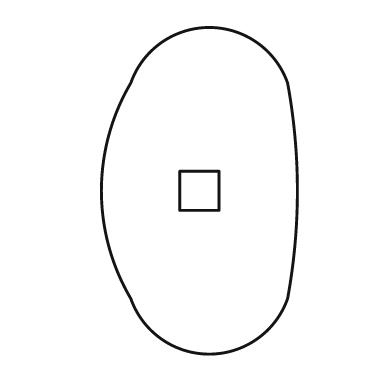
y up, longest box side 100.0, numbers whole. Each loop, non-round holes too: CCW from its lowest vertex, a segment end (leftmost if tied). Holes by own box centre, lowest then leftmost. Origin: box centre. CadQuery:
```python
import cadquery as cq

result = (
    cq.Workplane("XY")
    .moveTo(-21.0, -33.0)
    .threePointArc((3.0, -50.0), (27.0, -33.0))
    .threePointArc((30.0, 0.0), (27.0, 33.0))
    .threePointArc((3.0, 50.0), (-21.0, 33.0))
    .threePointArc((-30.0, 0.0), (-21.0, -33.0))
    .close()
    .moveTo(-6.0, -6.0)
    .lineTo(6.0, -6.0)
    .lineTo(6.0, 6.0)
    .lineTo(-6.0, 6.0)
    .close()
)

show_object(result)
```